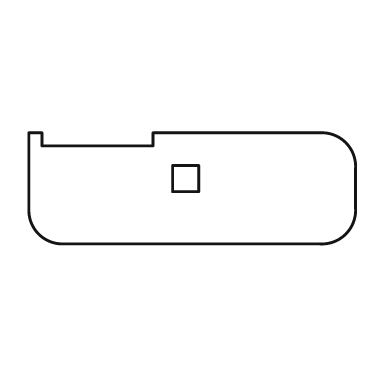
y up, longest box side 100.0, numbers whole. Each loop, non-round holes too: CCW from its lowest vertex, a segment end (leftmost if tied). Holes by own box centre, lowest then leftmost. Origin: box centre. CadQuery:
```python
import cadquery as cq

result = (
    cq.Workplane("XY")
    .moveTo(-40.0, -17.0)
    .lineTo(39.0, -17.0)
    .threePointArc((47.0, -14.0), (50.0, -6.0))
    .lineTo(50.0, 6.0)
    .threePointArc((47.0, 14.0), (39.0, 17.0))
    .lineTo(-12.0, 17.0)
    .lineTo(-12.0, 13.0)
    .lineTo(-46.0, 13.0)
    .lineTo(-46.0, 17.0)
    .lineTo(-50.0, 17.0)
    .lineTo(-50.0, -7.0)
    .threePointArc((-47.0, -14.0), (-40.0, -17.0))
    .close()
    .moveTo(-6.0, -1.0)
    .lineTo(2.0, -1.0)
    .lineTo(2.0, 7.0)
    .lineTo(-6.0, 7.0)
    .close()
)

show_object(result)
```